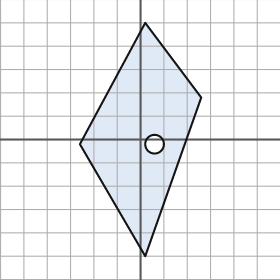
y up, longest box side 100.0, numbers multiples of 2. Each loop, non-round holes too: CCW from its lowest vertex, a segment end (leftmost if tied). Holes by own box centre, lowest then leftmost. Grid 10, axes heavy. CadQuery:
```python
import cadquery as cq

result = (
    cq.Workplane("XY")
    .moveTo(2.0, -50.0)
    .lineTo(26.0, 18.0)
    .lineTo(2.0, 50.0)
    .lineTo(-26.0, -2.0)
    .close()
    .moveTo(6.0, -2.0)
    .circle(4.0)
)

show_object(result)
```